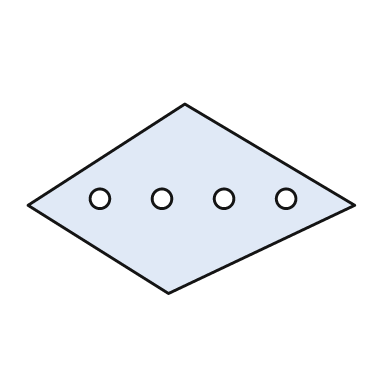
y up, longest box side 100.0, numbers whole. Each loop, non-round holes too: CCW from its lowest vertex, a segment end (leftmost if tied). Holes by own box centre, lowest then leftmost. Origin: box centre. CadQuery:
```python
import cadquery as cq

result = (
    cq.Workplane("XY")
    .moveTo(-7.0, -29.0)
    .lineTo(50.0, -2.0)
    .lineTo(-2.0, 29.0)
    .lineTo(-50.0, -2.0)
    .close()
    .moveTo(-28.0, 0.0)
    .circle(3.0)
    .moveTo(-9.0, 0.0)
    .circle(3.0)
    .moveTo(10.0, 0.0)
    .circle(3.0)
    .moveTo(29.0, 0.0)
    .circle(3.0)
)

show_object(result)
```